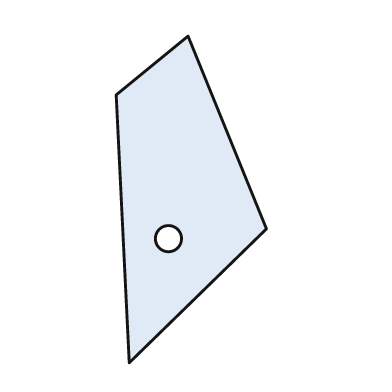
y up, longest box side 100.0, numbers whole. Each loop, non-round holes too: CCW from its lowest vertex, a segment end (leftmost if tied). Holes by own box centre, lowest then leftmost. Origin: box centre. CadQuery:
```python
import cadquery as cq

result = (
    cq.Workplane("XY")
    .moveTo(-19.0, -50.0)
    .lineTo(23.0, -9.0)
    .lineTo(-1.0, 50.0)
    .lineTo(-23.0, 32.0)
    .close()
    .moveTo(-7.0, -12.0)
    .circle(4.0)
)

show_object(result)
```